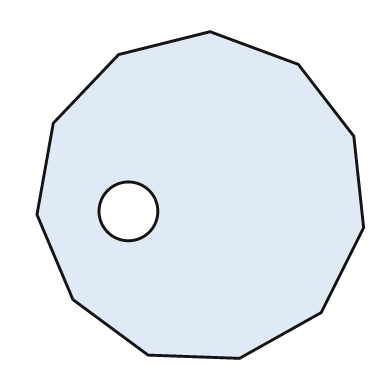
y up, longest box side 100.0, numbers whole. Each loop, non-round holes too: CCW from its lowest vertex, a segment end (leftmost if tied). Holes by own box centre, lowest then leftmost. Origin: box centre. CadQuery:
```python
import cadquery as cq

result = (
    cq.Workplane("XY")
    .moveTo(12.0, -50.0)
    .lineTo(37.0, -36.0)
    .lineTo(50.0, -10.0)
    .lineTo(47.0, 18.0)
    .lineTo(30.0, 40.0)
    .lineTo(3.0, 50.0)
    .lineTo(-25.0, 43.0)
    .lineTo(-45.0, 22.0)
    .lineTo(-50.0, -6.0)
    .lineTo(-39.0, -32.0)
    .lineTo(-16.0, -49.0)
    .close()
    .moveTo(-22.0, -5.0)
    .circle(9.0)
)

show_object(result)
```